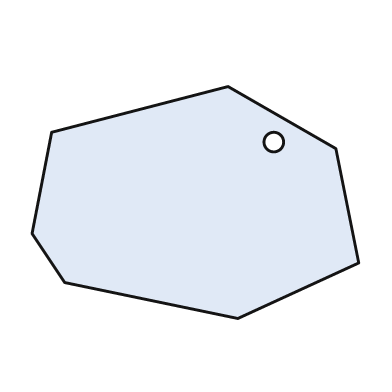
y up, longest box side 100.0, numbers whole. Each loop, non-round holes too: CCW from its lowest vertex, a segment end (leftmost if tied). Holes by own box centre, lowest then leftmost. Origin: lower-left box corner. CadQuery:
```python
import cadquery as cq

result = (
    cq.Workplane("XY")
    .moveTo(63.0, 0.0)
    .lineTo(100.0, 17.0)
    .lineTo(93.0, 52.0)
    .lineTo(60.0, 71.0)
    .lineTo(6.0, 57.0)
    .lineTo(0.0, 26.0)
    .lineTo(10.0, 11.0)
    .close()
    .moveTo(74.0, 54.0)
    .circle(3.0)
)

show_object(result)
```